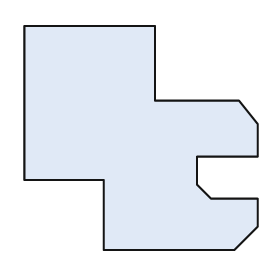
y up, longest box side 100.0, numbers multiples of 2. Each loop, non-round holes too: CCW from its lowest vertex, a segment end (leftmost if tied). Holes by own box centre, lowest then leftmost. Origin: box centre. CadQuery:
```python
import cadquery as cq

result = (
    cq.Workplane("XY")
    .moveTo(-16.0, -48.0)
    .lineTo(40.0, -48.0)
    .lineTo(50.0, -38.0)
    .lineTo(50.0, -26.0)
    .lineTo(30.0, -26.0)
    .lineTo(24.0, -20.0)
    .lineTo(24.0, -8.0)
    .lineTo(50.0, -8.0)
    .lineTo(50.0, 6.0)
    .lineTo(42.0, 16.0)
    .lineTo(6.0, 16.0)
    .lineTo(6.0, 48.0)
    .lineTo(-50.0, 48.0)
    .lineTo(-50.0, -18.0)
    .lineTo(-16.0, -18.0)
    .close()
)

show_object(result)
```